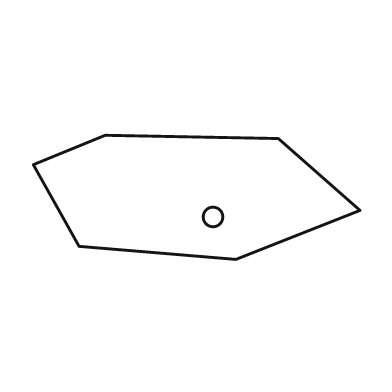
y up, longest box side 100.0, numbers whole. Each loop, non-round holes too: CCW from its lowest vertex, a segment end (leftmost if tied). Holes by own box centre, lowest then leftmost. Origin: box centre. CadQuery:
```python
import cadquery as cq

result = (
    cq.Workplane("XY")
    .moveTo(12.0, -19.0)
    .lineTo(50.0, -4.0)
    .lineTo(25.0, 18.0)
    .lineTo(-28.0, 19.0)
    .lineTo(-50.0, 10.0)
    .lineTo(-36.0, -15.0)
    .close()
    .moveTo(5.0, -6.0)
    .circle(3.0)
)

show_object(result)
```